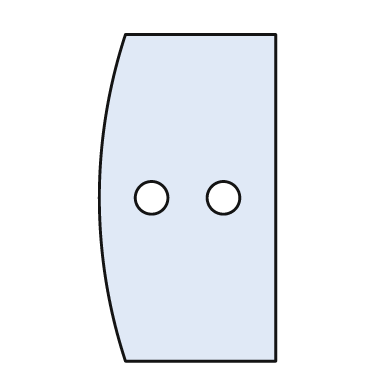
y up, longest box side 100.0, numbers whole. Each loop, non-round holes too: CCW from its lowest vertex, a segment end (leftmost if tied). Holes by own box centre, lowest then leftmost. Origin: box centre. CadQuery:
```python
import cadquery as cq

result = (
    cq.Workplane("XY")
    .moveTo(-19.0, -50.0)
    .lineTo(27.0, -50.0)
    .lineTo(27.0, 50.0)
    .lineTo(-19.0, 50.0)
    .threePointArc((-27.0, 0.0), (-19.0, -50.0))
    .close()
    .moveTo(-11.0, 0.0)
    .circle(5.0)
    .moveTo(11.0, 0.0)
    .circle(5.0)
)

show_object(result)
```